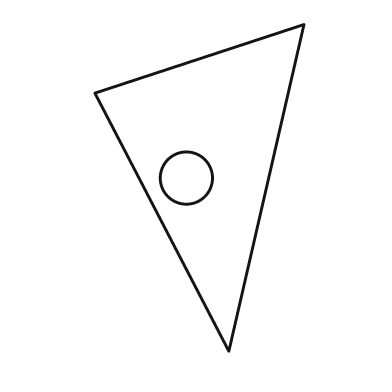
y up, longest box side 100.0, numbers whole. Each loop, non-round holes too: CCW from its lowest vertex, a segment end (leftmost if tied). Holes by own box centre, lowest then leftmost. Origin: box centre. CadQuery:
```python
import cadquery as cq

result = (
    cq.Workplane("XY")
    .moveTo(9.0, -50.0)
    .lineTo(32.0, 50.0)
    .lineTo(-32.0, 29.0)
    .close()
    .moveTo(-4.0, 3.0)
    .circle(8.0)
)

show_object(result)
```